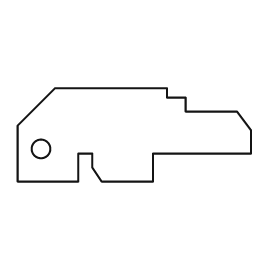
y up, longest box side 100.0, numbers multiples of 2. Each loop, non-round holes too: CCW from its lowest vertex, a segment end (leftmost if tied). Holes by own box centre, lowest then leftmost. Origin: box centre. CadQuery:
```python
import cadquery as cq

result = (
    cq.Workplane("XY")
    .moveTo(-50.0, -20.0)
    .lineTo(-24.0, -20.0)
    .lineTo(-24.0, -8.0)
    .lineTo(-18.0, -8.0)
    .lineTo(-18.0, -14.0)
    .lineTo(-14.0, -20.0)
    .lineTo(8.0, -20.0)
    .lineTo(8.0, -8.0)
    .lineTo(50.0, -8.0)
    .lineTo(50.0, 2.0)
    .lineTo(44.0, 10.0)
    .lineTo(22.0, 10.0)
    .lineTo(22.0, 16.0)
    .lineTo(14.0, 16.0)
    .lineTo(14.0, 20.0)
    .lineTo(-34.0, 20.0)
    .lineTo(-50.0, 4.0)
    .close()
    .moveTo(-40.0, -6.0)
    .circle(4.0)
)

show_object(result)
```